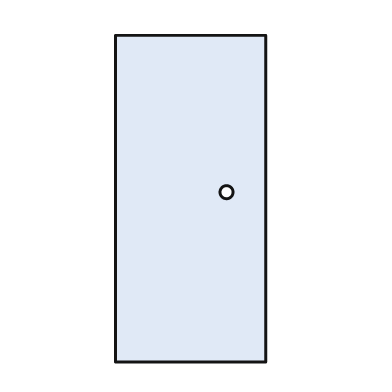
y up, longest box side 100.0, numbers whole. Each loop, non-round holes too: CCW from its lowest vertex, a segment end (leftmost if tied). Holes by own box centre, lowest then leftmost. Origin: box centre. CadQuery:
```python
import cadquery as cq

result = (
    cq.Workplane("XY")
    .moveTo(-23.0, -50.0)
    .lineTo(23.0, -50.0)
    .lineTo(23.0, 50.0)
    .lineTo(-23.0, 50.0)
    .close()
    .moveTo(11.0, 2.0)
    .circle(2.0)
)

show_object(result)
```